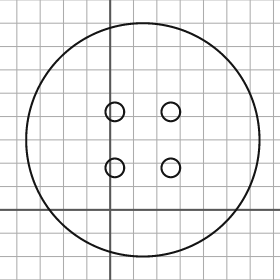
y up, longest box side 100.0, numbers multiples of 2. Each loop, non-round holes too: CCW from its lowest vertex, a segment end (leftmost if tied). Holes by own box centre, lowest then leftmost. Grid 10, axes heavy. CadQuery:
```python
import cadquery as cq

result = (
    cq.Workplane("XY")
    .moveTo(14.0, 30.0)
    .circle(50.0)
    .moveTo(2.0, 18.0)
    .circle(4.0)
    .moveTo(26.0, 18.0)
    .circle(4.0)
    .moveTo(2.0, 42.0)
    .circle(4.0)
    .moveTo(26.0, 42.0)
    .circle(4.0)
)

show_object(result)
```